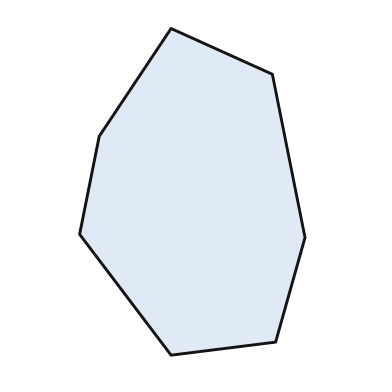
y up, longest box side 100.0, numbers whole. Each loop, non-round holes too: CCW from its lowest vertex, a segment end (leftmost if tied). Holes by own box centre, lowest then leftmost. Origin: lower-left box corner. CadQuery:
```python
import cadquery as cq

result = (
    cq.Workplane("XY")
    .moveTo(28.0, 0.0)
    .lineTo(60.0, 4.0)
    .lineTo(69.0, 36.0)
    .lineTo(59.0, 86.0)
    .lineTo(28.0, 100.0)
    .lineTo(6.0, 67.0)
    .lineTo(0.0, 37.0)
    .close()
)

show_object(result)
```